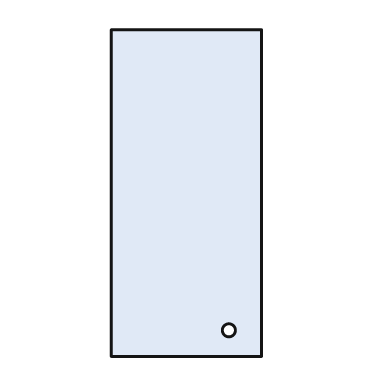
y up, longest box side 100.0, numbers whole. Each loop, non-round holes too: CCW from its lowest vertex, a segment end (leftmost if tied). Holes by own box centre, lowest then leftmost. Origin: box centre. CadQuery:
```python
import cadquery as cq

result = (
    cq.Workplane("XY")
    .moveTo(-23.0, -50.0)
    .lineTo(23.0, -50.0)
    .lineTo(23.0, 50.0)
    .lineTo(-23.0, 50.0)
    .close()
    .moveTo(13.0, -42.0)
    .circle(2.0)
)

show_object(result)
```